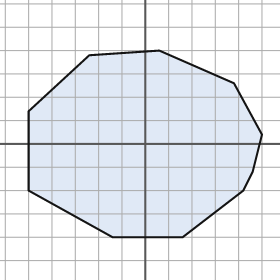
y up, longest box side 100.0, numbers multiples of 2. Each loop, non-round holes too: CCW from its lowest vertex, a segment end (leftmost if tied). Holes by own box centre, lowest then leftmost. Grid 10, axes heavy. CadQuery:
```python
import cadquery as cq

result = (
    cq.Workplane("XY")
    .moveTo(-14.0, -40.0)
    .lineTo(16.0, -40.0)
    .lineTo(42.0, -20.0)
    .lineTo(46.0, -12.0)
    .lineTo(50.0, 4.0)
    .lineTo(38.0, 26.0)
    .lineTo(6.0, 40.0)
    .lineTo(-24.0, 38.0)
    .lineTo(-50.0, 14.0)
    .lineTo(-50.0, -20.0)
    .close()
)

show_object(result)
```